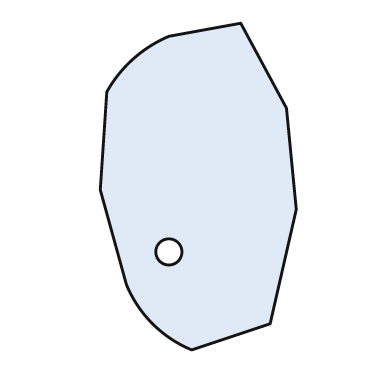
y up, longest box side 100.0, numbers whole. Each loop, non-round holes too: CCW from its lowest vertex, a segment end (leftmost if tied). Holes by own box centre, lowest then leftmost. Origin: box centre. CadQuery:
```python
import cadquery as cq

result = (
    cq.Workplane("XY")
    .moveTo(-2.0, -50.0)
    .lineTo(22.0, -42.0)
    .lineTo(30.0, -7.0)
    .lineTo(27.0, 24.0)
    .lineTo(13.0, 50.0)
    .lineTo(-9.0, 46.0)
    .threePointArc((-20.0, 39.0), (-28.0, 29.0))
    .lineTo(-30.0, -1.0)
    .lineTo(-22.0, -30.0)
    .threePointArc((-14.0, -42.0), (-2.0, -50.0))
    .close()
    .moveTo(-9.0, -20.0)
    .circle(4.0)
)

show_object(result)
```